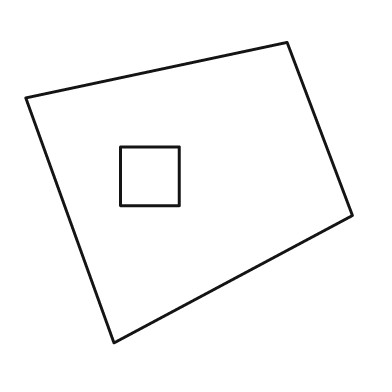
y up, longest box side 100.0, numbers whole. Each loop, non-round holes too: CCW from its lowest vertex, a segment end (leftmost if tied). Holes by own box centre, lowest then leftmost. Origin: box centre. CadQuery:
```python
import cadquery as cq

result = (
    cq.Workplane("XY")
    .moveTo(-23.0, -46.0)
    .lineTo(50.0, -7.0)
    .lineTo(30.0, 46.0)
    .lineTo(-50.0, 29.0)
    .close()
    .moveTo(-21.0, -4.0)
    .lineTo(-3.0, -4.0)
    .lineTo(-3.0, 14.0)
    .lineTo(-21.0, 14.0)
    .close()
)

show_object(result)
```